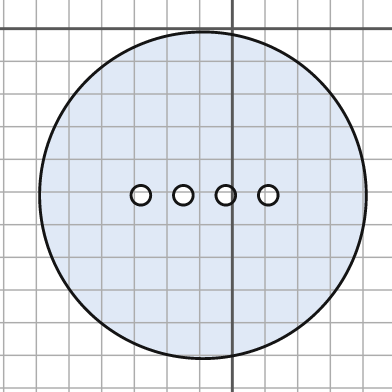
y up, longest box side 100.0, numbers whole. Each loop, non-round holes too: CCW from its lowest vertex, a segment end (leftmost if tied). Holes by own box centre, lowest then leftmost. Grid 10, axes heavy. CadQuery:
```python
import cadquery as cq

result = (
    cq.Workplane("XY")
    .moveTo(-9.0, -51.0)
    .circle(50.0)
    .moveTo(-28.0, -51.0)
    .circle(3.0)
    .moveTo(-15.0, -51.0)
    .circle(3.0)
    .moveTo(-2.0, -51.0)
    .circle(3.0)
    .moveTo(11.0, -51.0)
    .circle(3.0)
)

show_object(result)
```